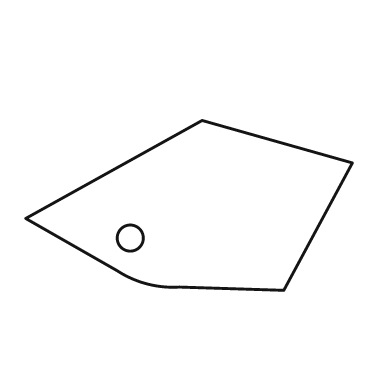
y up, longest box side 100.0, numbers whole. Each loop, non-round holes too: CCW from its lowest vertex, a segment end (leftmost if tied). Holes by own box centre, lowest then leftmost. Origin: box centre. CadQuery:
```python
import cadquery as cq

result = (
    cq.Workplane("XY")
    .moveTo(29.0, -26.0)
    .lineTo(50.0, 13.0)
    .lineTo(4.0, 26.0)
    .lineTo(-50.0, -4.0)
    .lineTo(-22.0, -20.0)
    .threePointArc((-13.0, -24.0), (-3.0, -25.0))
    .close()
    .moveTo(-18.0, -10.0)
    .circle(4.0)
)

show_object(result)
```